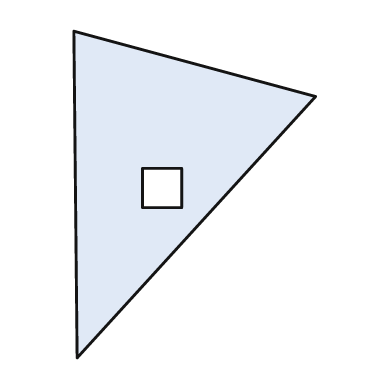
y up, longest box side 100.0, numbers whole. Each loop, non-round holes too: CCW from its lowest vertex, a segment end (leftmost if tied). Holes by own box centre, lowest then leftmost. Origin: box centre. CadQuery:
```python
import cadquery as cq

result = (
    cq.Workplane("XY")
    .moveTo(-36.0, -50.0)
    .lineTo(37.0, 30.0)
    .lineTo(-37.0, 50.0)
    .close()
    .moveTo(-16.0, -4.0)
    .lineTo(-4.0, -4.0)
    .lineTo(-4.0, 8.0)
    .lineTo(-16.0, 8.0)
    .close()
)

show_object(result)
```